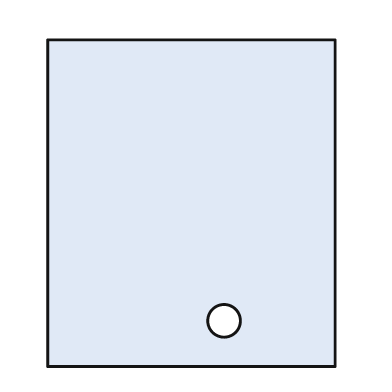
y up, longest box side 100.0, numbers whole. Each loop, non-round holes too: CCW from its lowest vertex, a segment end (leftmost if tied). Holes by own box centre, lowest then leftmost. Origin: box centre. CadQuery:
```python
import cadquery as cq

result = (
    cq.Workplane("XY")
    .moveTo(-44.0, -50.0)
    .lineTo(44.0, -50.0)
    .lineTo(44.0, 50.0)
    .lineTo(-44.0, 50.0)
    .close()
    .moveTo(10.0, -36.0)
    .circle(5.0)
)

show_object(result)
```